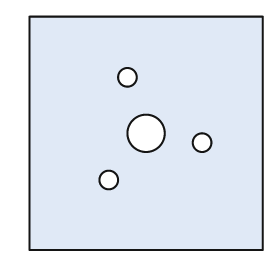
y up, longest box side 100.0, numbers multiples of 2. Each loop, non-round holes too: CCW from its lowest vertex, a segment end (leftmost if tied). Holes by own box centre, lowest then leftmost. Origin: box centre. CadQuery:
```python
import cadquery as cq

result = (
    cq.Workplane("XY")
    .moveTo(-50.0, -50.0)
    .lineTo(50.0, -50.0)
    .lineTo(50.0, 50.0)
    .lineTo(-50.0, 50.0)
    .close()
    .moveTo(-16.0, -20.0)
    .circle(4.0)
    .moveTo(24.0, -4.0)
    .circle(4.0)
    .moveTo(0.0, 0.0)
    .circle(8.0)
    .moveTo(-8.0, 24.0)
    .circle(4.0)
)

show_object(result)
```